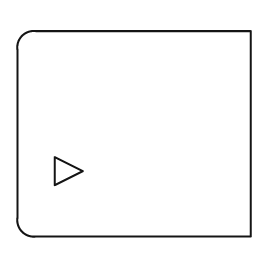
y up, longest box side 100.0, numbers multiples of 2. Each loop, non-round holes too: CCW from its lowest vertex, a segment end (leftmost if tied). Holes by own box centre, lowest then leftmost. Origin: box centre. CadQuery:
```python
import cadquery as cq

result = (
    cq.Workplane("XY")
    .moveTo(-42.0, -44.0)
    .lineTo(50.0, -44.0)
    .lineTo(50.0, 44.0)
    .lineTo(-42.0, 44.0)
    .threePointArc((-48.0, 42.0), (-50.0, 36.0))
    .lineTo(-50.0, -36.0)
    .threePointArc((-48.0, -42.0), (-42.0, -44.0))
    .close()
    .moveTo(-34.0, -22.0)
    .lineTo(-22.0, -16.0)
    .lineTo(-34.0, -10.0)
    .close()
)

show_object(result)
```